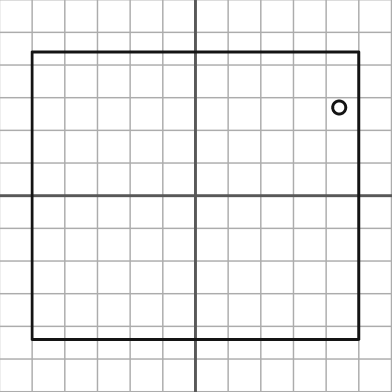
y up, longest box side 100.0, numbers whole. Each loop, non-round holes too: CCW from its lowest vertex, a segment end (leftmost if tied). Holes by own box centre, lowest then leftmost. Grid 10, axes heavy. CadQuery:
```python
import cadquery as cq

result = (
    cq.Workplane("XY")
    .moveTo(-50.0, -44.0)
    .lineTo(50.0, -44.0)
    .lineTo(50.0, 44.0)
    .lineTo(-50.0, 44.0)
    .close()
    .moveTo(44.0, 27.0)
    .circle(2.0)
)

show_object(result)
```